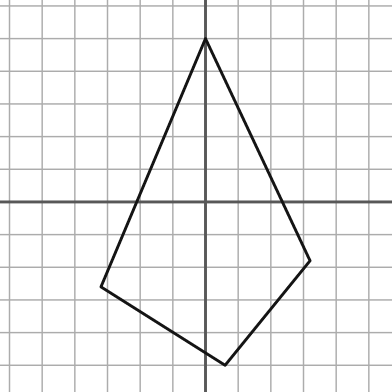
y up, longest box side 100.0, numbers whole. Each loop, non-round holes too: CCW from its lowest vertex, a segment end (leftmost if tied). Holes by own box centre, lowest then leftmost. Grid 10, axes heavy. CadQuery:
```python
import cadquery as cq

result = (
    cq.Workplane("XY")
    .moveTo(6.0, -50.0)
    .lineTo(32.0, -18.0)
    .lineTo(0.0, 50.0)
    .lineTo(-32.0, -26.0)
    .close()
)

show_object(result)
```